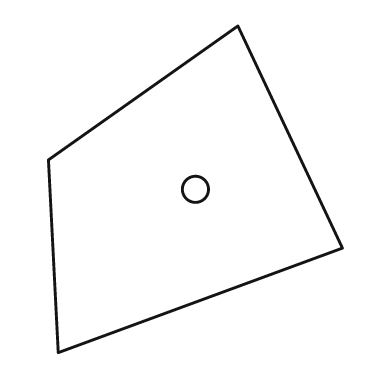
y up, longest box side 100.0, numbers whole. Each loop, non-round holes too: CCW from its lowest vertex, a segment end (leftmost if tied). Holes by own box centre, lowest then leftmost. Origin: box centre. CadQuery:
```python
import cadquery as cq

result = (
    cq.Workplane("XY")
    .moveTo(-42.0, -50.0)
    .lineTo(45.0, -18.0)
    .lineTo(13.0, 50.0)
    .lineTo(-45.0, 9.0)
    .close()
    .moveTo(0.0, 0.0)
    .circle(4.0)
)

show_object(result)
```